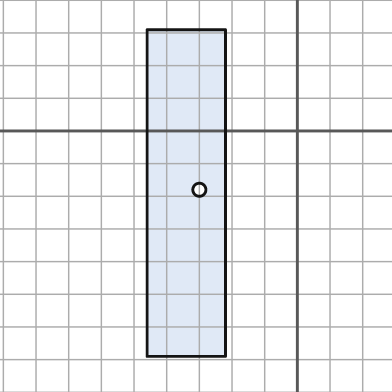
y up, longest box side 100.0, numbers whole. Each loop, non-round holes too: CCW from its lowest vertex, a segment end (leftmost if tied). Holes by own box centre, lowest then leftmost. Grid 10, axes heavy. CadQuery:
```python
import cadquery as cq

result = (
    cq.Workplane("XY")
    .moveTo(-46.0, -69.0)
    .lineTo(-22.0, -69.0)
    .lineTo(-22.0, 31.0)
    .lineTo(-46.0, 31.0)
    .close()
    .moveTo(-30.0, -18.0)
    .circle(2.0)
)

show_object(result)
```